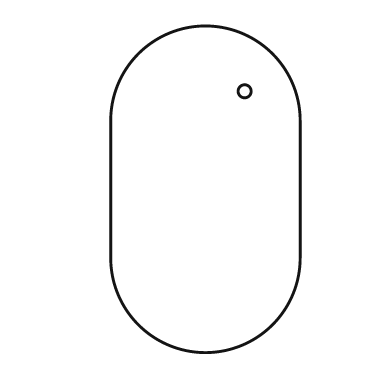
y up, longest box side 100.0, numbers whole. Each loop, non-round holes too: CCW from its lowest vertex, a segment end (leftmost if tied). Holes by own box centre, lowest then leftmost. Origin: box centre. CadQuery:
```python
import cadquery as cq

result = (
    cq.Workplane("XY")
    .moveTo(-29.0, -21.0)
    .threePointArc((0.0, -50.0), (29.0, -21.0))
    .lineTo(29.0, 21.0)
    .threePointArc((0.0, 50.0), (-29.0, 21.0))
    .close()
    .moveTo(12.0, 30.0)
    .circle(2.0)
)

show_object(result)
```